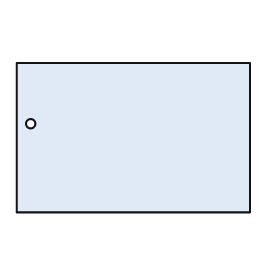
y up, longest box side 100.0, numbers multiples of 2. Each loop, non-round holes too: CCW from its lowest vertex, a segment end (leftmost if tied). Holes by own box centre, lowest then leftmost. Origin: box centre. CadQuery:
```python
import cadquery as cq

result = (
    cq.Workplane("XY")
    .moveTo(-50.0, -32.0)
    .lineTo(50.0, -32.0)
    .lineTo(50.0, 32.0)
    .lineTo(-50.0, 32.0)
    .close()
    .moveTo(-44.0, 6.0)
    .circle(2.0)
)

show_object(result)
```